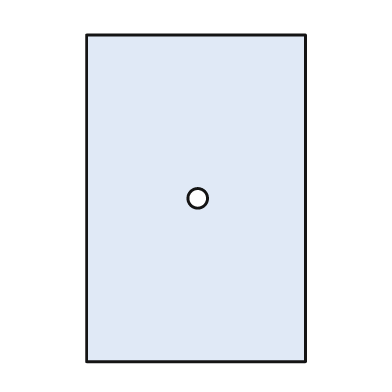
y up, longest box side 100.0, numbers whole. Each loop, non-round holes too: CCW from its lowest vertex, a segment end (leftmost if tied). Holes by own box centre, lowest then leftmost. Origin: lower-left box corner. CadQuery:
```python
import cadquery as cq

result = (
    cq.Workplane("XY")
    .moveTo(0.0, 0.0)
    .lineTo(67.0, 0.0)
    .lineTo(67.0, 100.0)
    .lineTo(0.0, 100.0)
    .close()
    .moveTo(34.0, 50.0)
    .circle(3.0)
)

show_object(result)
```